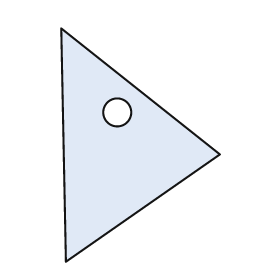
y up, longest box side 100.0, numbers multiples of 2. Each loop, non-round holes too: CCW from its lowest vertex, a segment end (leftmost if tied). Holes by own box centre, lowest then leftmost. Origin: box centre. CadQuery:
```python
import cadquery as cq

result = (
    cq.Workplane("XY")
    .moveTo(-32.0, -50.0)
    .lineTo(34.0, -4.0)
    .lineTo(-34.0, 50.0)
    .close()
    .moveTo(-10.0, 14.0)
    .circle(6.0)
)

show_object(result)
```